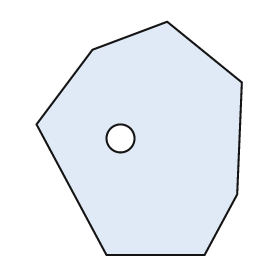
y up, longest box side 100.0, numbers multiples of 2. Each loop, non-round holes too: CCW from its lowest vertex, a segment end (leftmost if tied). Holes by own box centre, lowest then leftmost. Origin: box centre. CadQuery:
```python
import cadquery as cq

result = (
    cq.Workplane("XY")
    .moveTo(-14.0, -50.0)
    .lineTo(28.0, -50.0)
    .lineTo(42.0, -24.0)
    .lineTo(44.0, 24.0)
    .lineTo(12.0, 50.0)
    .lineTo(-20.0, 38.0)
    .lineTo(-44.0, 6.0)
    .close()
    .moveTo(-8.0, 0.0)
    .circle(6.0)
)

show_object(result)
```